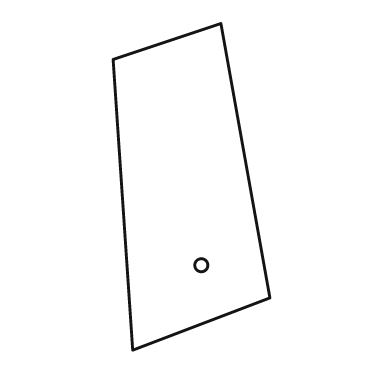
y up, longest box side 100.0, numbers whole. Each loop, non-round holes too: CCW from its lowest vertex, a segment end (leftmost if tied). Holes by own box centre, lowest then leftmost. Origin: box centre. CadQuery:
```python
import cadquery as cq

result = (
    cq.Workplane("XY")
    .moveTo(-18.0, -50.0)
    .lineTo(24.0, -34.0)
    .lineTo(9.0, 50.0)
    .lineTo(-24.0, 39.0)
    .close()
    .moveTo(3.0, -24.0)
    .circle(2.0)
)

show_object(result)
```